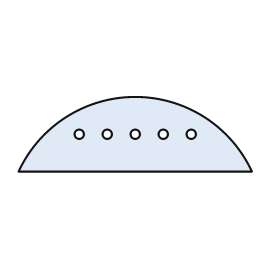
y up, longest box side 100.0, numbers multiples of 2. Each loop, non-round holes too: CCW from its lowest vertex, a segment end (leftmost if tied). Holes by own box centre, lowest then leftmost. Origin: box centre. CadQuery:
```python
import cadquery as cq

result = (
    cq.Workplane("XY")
    .moveTo(-50.0, -16.0)
    .lineTo(50.0, -16.0)
    .threePointArc((0.0, 16.0), (-50.0, -16.0))
    .close()
    .moveTo(-24.0, 0.0)
    .circle(2.0)
    .moveTo(-12.0, 0.0)
    .circle(2.0)
    .moveTo(0.0, 0.0)
    .circle(2.0)
    .moveTo(12.0, 0.0)
    .circle(2.0)
    .moveTo(24.0, 0.0)
    .circle(2.0)
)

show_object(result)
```